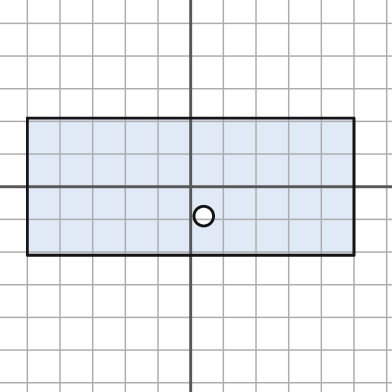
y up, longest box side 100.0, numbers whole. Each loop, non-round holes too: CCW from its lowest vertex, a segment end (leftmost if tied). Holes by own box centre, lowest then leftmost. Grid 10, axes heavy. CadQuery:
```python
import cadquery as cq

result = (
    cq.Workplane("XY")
    .moveTo(-50.0, -21.0)
    .lineTo(50.0, -21.0)
    .lineTo(50.0, 21.0)
    .lineTo(-50.0, 21.0)
    .close()
    .moveTo(4.0, -9.0)
    .circle(3.0)
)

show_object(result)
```